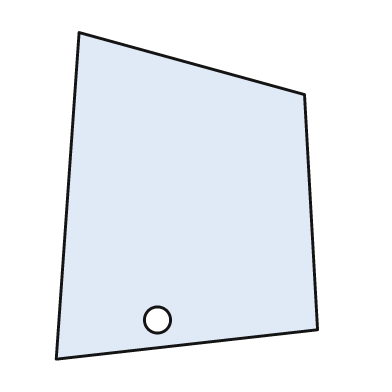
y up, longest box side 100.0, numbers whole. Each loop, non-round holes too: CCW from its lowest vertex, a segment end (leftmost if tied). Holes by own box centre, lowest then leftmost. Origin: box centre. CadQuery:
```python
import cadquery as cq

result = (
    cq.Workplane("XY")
    .moveTo(-40.0, -50.0)
    .lineTo(40.0, -41.0)
    .lineTo(36.0, 31.0)
    .lineTo(-33.0, 50.0)
    .close()
    .moveTo(-9.0, -38.0)
    .circle(4.0)
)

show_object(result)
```